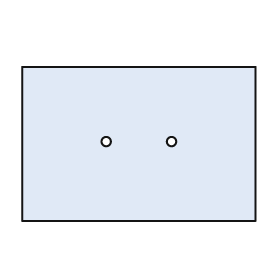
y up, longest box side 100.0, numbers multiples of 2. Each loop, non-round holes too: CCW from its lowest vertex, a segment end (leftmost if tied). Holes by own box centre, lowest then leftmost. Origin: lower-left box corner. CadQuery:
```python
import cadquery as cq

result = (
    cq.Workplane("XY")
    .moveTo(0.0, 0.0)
    .lineTo(100.0, 0.0)
    .lineTo(100.0, 66.0)
    .lineTo(0.0, 66.0)
    .close()
    .moveTo(36.0, 34.0)
    .circle(2.0)
    .moveTo(64.0, 34.0)
    .circle(2.0)
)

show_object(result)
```